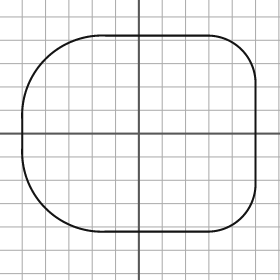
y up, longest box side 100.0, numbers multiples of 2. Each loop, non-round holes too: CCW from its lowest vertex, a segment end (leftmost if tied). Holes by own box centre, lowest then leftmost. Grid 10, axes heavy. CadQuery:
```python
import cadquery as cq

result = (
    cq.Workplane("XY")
    .moveTo(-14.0, -42.0)
    .lineTo(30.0, -42.0)
    .threePointArc((44.0, -36.0), (50.0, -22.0))
    .lineTo(50.0, 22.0)
    .threePointArc((44.0, 36.0), (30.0, 42.0))
    .lineTo(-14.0, 42.0)
    .threePointArc((-40.0, 32.0), (-50.0, 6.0))
    .lineTo(-50.0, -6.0)
    .threePointArc((-40.0, -32.0), (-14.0, -42.0))
    .close()
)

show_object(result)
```